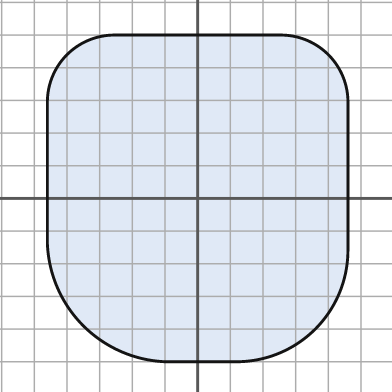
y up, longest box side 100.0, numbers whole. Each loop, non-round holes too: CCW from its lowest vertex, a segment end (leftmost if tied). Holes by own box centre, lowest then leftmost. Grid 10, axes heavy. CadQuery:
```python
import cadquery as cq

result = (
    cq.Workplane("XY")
    .moveTo(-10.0, -50.0)
    .lineTo(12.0, -50.0)
    .threePointArc((36.0, -40.0), (46.0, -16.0))
    .lineTo(46.0, 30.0)
    .threePointArc((40.0, 44.0), (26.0, 50.0))
    .lineTo(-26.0, 50.0)
    .threePointArc((-40.0, 44.0), (-46.0, 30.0))
    .lineTo(-46.0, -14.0)
    .threePointArc((-35.0, -39.0), (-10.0, -50.0))
    .close()
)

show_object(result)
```